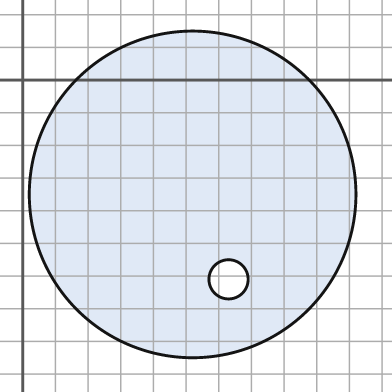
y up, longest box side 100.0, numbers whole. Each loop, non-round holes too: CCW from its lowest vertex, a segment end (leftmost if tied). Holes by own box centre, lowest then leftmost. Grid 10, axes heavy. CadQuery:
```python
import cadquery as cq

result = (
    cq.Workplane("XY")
    .moveTo(52.0, -35.0)
    .circle(50.0)
    .moveTo(63.0, -61.0)
    .circle(6.0)
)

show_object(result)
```